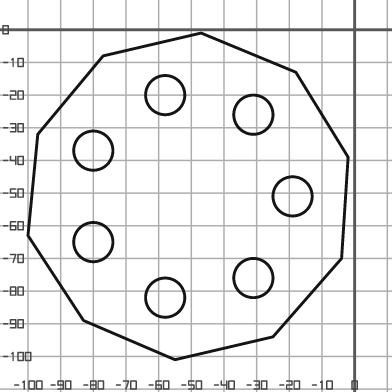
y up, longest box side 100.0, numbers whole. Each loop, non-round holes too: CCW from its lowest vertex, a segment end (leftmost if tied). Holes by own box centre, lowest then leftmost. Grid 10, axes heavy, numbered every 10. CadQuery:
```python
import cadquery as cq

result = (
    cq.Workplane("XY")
    .moveTo(-55.0, -101.0)
    .lineTo(-25.0, -94.0)
    .lineTo(-4.0, -70.0)
    .lineTo(-2.0, -39.0)
    .lineTo(-18.0, -13.0)
    .lineTo(-47.0, -1.0)
    .lineTo(-77.0, -8.0)
    .lineTo(-97.0, -32.0)
    .lineTo(-100.0, -63.0)
    .lineTo(-83.0, -89.0)
    .close()
    .moveTo(-58.0, -82.0)
    .circle(6.0)
    .moveTo(-31.0, -76.0)
    .circle(6.0)
    .moveTo(-80.0, -65.0)
    .circle(6.0)
    .moveTo(-19.0, -51.0)
    .circle(6.0)
    .moveTo(-80.0, -37.0)
    .circle(6.0)
    .moveTo(-31.0, -26.0)
    .circle(6.0)
    .moveTo(-58.0, -20.0)
    .circle(6.0)
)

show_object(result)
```